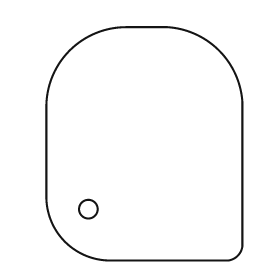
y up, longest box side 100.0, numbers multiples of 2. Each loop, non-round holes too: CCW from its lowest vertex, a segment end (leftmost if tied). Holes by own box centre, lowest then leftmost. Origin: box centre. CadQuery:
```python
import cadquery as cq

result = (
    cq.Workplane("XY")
    .moveTo(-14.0, -50.0)
    .lineTo(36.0, -50.0)
    .threePointArc((40.0, -48.0), (42.0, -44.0))
    .lineTo(42.0, 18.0)
    .threePointArc((32.0, 40.0), (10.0, 50.0))
    .lineTo(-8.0, 50.0)
    .threePointArc((-32.0, 40.0), (-42.0, 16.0))
    .lineTo(-42.0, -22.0)
    .threePointArc((-34.0, -42.0), (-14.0, -50.0))
    .close()
    .moveTo(-24.0, -28.0)
    .circle(4.0)
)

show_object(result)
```